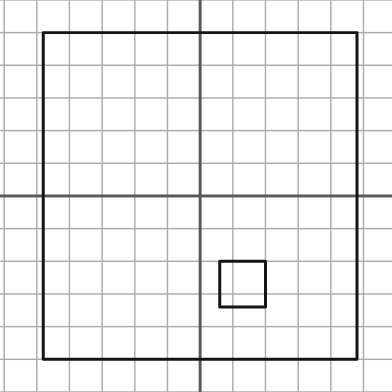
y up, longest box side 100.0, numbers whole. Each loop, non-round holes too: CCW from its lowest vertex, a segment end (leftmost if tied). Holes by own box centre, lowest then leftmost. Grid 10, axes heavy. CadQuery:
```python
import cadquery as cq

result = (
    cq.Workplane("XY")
    .moveTo(-48.0, -50.0)
    .lineTo(48.0, -50.0)
    .lineTo(48.0, 50.0)
    .lineTo(-48.0, 50.0)
    .close()
    .moveTo(6.0, -34.0)
    .lineTo(20.0, -34.0)
    .lineTo(20.0, -20.0)
    .lineTo(6.0, -20.0)
    .close()
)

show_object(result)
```